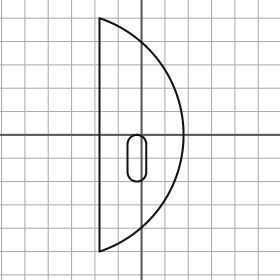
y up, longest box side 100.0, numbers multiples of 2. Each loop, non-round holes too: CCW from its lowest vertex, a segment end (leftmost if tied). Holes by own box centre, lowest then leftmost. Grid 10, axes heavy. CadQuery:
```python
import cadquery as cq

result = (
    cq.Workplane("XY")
    .moveTo(-18.0, -50.0)
    .threePointArc((18.0, 0.0), (-18.0, 50.0))
    .close()
    .moveTo(-6.0, -16.0)
    .threePointArc((-2.0, -20.0), (2.0, -16.0))
    .lineTo(2.0, -4.0)
    .threePointArc((-2.0, 0.0), (-6.0, -4.0))
    .close()
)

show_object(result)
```